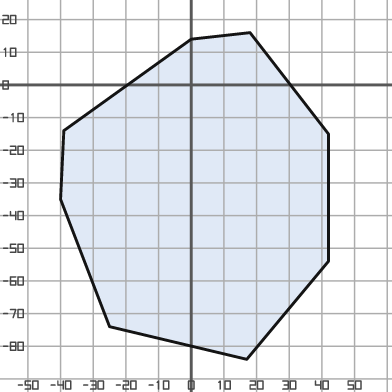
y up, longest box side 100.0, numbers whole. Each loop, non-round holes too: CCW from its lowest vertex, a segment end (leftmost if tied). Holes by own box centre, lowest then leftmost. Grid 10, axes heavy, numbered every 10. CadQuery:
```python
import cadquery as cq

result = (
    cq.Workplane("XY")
    .moveTo(17.0, -84.0)
    .lineTo(42.0, -54.0)
    .lineTo(42.0, -15.0)
    .lineTo(18.0, 16.0)
    .lineTo(0.0, 14.0)
    .lineTo(-39.0, -14.0)
    .lineTo(-40.0, -35.0)
    .lineTo(-25.0, -74.0)
    .close()
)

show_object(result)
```